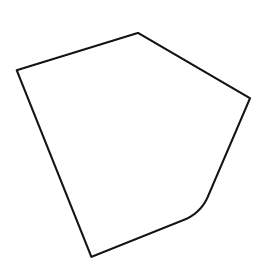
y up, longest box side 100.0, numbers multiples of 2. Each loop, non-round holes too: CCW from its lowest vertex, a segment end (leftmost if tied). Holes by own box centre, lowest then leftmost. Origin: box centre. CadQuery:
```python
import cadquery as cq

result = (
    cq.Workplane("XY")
    .moveTo(-18.0, -48.0)
    .lineTo(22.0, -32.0)
    .threePointArc((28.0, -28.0), (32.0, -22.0))
    .lineTo(50.0, 20.0)
    .lineTo(2.0, 48.0)
    .lineTo(-50.0, 32.0)
    .close()
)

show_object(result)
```